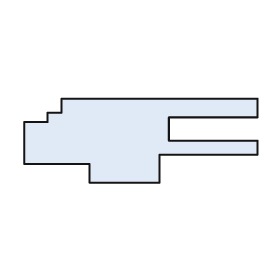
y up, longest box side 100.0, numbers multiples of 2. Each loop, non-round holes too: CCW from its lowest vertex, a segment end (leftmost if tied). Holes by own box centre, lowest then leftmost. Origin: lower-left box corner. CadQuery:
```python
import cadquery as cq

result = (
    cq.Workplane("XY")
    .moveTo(28.0, 0.0)
    .lineTo(58.0, 0.0)
    .lineTo(58.0, 12.0)
    .lineTo(100.0, 12.0)
    .lineTo(100.0, 18.0)
    .lineTo(62.0, 18.0)
    .lineTo(62.0, 28.0)
    .lineTo(100.0, 28.0)
    .lineTo(100.0, 36.0)
    .lineTo(16.0, 36.0)
    .lineTo(16.0, 30.0)
    .lineTo(10.0, 30.0)
    .lineTo(10.0, 26.0)
    .lineTo(0.0, 26.0)
    .lineTo(0.0, 8.0)
    .lineTo(28.0, 8.0)
    .close()
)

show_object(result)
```